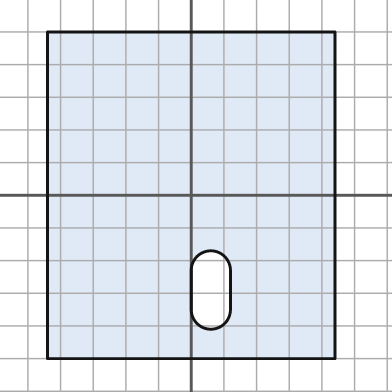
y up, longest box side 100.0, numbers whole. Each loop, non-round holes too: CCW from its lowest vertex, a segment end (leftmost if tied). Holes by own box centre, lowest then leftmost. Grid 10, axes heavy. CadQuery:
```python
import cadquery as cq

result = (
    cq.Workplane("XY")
    .moveTo(-44.0, -50.0)
    .lineTo(44.0, -50.0)
    .lineTo(44.0, 50.0)
    .lineTo(-44.0, 50.0)
    .close()
    .moveTo(0.0, -35.0)
    .threePointArc((6.0, -41.0), (12.0, -35.0))
    .lineTo(12.0, -23.0)
    .threePointArc((6.0, -17.0), (0.0, -23.0))
    .close()
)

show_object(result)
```